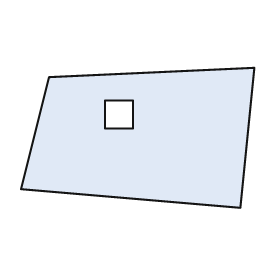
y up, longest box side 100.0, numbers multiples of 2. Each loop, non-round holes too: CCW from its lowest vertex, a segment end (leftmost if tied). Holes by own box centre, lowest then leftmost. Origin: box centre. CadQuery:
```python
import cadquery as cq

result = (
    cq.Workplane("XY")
    .moveTo(44.0, -30.0)
    .lineTo(50.0, 30.0)
    .lineTo(-38.0, 26.0)
    .lineTo(-50.0, -22.0)
    .close()
    .moveTo(-14.0, 4.0)
    .lineTo(-2.0, 4.0)
    .lineTo(-2.0, 16.0)
    .lineTo(-14.0, 16.0)
    .close()
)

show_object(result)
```